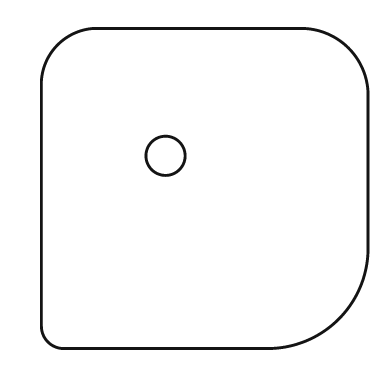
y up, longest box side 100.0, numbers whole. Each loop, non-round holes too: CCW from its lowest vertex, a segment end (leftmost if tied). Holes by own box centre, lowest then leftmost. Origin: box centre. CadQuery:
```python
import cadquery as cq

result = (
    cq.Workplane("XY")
    .moveTo(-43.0, -49.0)
    .lineTo(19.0, -49.0)
    .threePointArc((41.0, -40.0), (50.0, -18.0))
    .lineTo(50.0, 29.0)
    .threePointArc((44.0, 43.0), (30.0, 49.0))
    .lineTo(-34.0, 49.0)
    .threePointArc((-45.0, 44.0), (-50.0, 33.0))
    .lineTo(-50.0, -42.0)
    .threePointArc((-48.0, -47.0), (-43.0, -49.0))
    .close()
    .moveTo(-12.0, 10.0)
    .circle(6.0)
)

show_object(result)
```